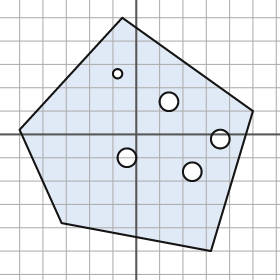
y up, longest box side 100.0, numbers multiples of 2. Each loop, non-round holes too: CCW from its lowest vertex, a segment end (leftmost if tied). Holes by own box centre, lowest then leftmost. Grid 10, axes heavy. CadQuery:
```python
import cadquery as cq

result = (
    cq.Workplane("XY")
    .moveTo(32.0, -50.0)
    .lineTo(50.0, 10.0)
    .lineTo(-6.0, 50.0)
    .lineTo(-50.0, 2.0)
    .lineTo(-32.0, -38.0)
    .close()
    .moveTo(24.0, -16.0)
    .circle(4.0)
    .moveTo(-4.0, -10.0)
    .circle(4.0)
    .moveTo(36.0, -2.0)
    .circle(4.0)
    .moveTo(14.0, 14.0)
    .circle(4.0)
    .moveTo(-8.0, 26.0)
    .circle(2.0)
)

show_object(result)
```